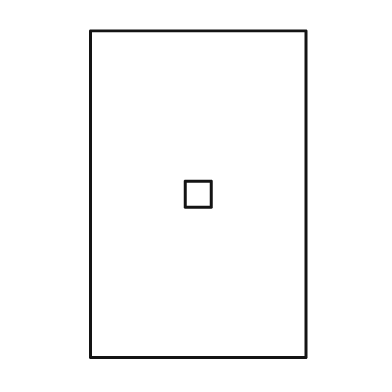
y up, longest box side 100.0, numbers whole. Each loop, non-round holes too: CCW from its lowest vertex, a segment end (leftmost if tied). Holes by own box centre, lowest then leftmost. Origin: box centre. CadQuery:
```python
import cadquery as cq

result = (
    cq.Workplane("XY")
    .moveTo(-33.0, -50.0)
    .lineTo(33.0, -50.0)
    .lineTo(33.0, 50.0)
    .lineTo(-33.0, 50.0)
    .close()
    .moveTo(-4.0, -4.0)
    .lineTo(4.0, -4.0)
    .lineTo(4.0, 4.0)
    .lineTo(-4.0, 4.0)
    .close()
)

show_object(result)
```